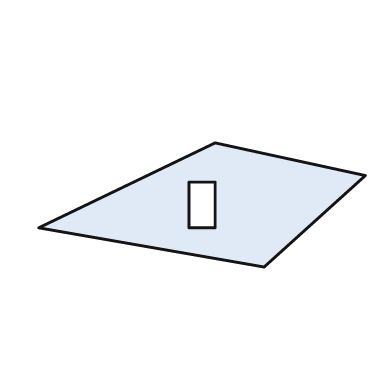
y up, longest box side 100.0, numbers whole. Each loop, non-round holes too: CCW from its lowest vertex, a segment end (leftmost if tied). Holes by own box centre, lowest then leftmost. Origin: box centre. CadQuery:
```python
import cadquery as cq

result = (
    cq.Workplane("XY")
    .moveTo(19.0, -19.0)
    .lineTo(50.0, 9.0)
    .lineTo(4.0, 19.0)
    .lineTo(-50.0, -7.0)
    .close()
    .moveTo(-4.0, -7.0)
    .lineTo(4.0, -7.0)
    .lineTo(4.0, 7.0)
    .lineTo(-4.0, 7.0)
    .close()
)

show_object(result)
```